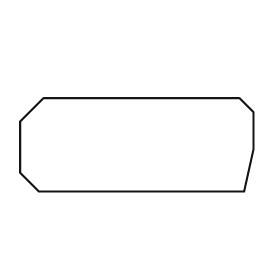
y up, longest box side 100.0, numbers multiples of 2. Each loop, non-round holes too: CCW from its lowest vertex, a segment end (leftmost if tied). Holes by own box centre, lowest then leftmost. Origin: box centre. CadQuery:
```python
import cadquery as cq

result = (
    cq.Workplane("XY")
    .moveTo(-42.0, -20.0)
    .lineTo(46.0, -20.0)
    .lineTo(50.0, -2.0)
    .lineTo(50.0, 14.0)
    .lineTo(44.0, 20.0)
    .lineTo(-40.0, 20.0)
    .lineTo(-50.0, 10.0)
    .lineTo(-50.0, -12.0)
    .close()
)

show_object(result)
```